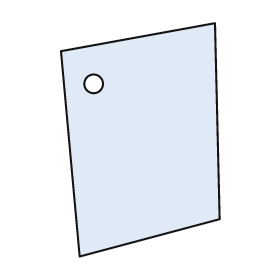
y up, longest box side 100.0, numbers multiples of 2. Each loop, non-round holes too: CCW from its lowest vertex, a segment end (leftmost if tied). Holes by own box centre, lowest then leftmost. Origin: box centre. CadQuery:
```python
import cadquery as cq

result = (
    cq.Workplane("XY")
    .moveTo(-26.0, -50.0)
    .lineTo(34.0, -34.0)
    .lineTo(32.0, 50.0)
    .lineTo(-34.0, 38.0)
    .close()
    .moveTo(-20.0, 24.0)
    .circle(4.0)
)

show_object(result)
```